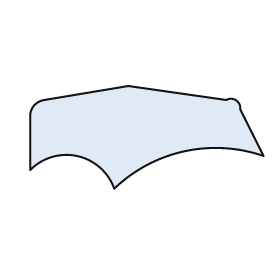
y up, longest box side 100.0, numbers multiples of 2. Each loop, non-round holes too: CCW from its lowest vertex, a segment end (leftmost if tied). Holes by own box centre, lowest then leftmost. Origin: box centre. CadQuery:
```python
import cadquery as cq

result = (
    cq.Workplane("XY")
    .moveTo(-14.0, -22.0)
    .threePointArc((16.0, -6.0), (50.0, -8.0))
    .lineTo(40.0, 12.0)
    .threePointArc((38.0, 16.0), (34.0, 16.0))
    .lineTo(-8.0, 22.0)
    .lineTo(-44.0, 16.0)
    .threePointArc((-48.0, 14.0), (-50.0, 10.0))
    .lineTo(-50.0, -14.0)
    .threePointArc((-30.0, -8.0), (-14.0, -22.0))
    .close()
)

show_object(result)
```